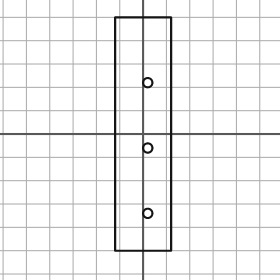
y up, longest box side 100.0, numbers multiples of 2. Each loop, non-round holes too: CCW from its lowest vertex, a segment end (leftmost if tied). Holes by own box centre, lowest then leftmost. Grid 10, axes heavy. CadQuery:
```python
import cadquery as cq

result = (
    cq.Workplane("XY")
    .moveTo(-12.0, -50.0)
    .lineTo(12.0, -50.0)
    .lineTo(12.0, 50.0)
    .lineTo(-12.0, 50.0)
    .close()
    .moveTo(2.0, -34.0)
    .circle(2.0)
    .moveTo(2.0, -6.0)
    .circle(2.0)
    .moveTo(2.0, 22.0)
    .circle(2.0)
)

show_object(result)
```